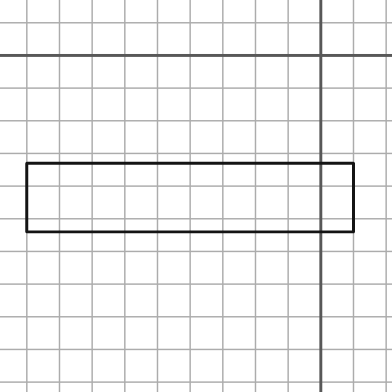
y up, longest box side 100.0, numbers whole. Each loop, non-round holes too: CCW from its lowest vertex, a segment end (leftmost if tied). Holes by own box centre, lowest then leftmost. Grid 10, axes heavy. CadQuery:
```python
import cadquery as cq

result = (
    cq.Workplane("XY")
    .moveTo(-90.0, -54.0)
    .lineTo(10.0, -54.0)
    .lineTo(10.0, -33.0)
    .lineTo(-90.0, -33.0)
    .close()
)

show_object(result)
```